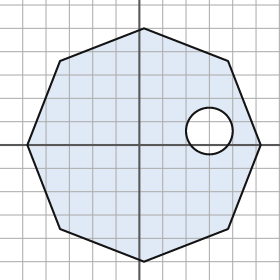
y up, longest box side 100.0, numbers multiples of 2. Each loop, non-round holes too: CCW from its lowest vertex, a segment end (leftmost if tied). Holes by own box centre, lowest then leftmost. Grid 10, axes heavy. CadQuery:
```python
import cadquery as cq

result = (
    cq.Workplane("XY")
    .moveTo(2.0, -50.0)
    .lineTo(38.0, -36.0)
    .lineTo(52.0, 0.0)
    .lineTo(38.0, 36.0)
    .lineTo(2.0, 50.0)
    .lineTo(-34.0, 36.0)
    .lineTo(-48.0, 0.0)
    .lineTo(-34.0, -36.0)
    .close()
    .moveTo(30.0, 6.0)
    .circle(10.0)
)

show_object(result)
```